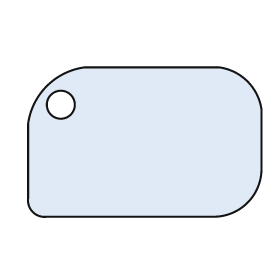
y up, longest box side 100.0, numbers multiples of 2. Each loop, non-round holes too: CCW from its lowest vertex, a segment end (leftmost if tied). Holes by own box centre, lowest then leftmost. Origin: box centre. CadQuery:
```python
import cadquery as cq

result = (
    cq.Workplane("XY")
    .moveTo(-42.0, -32.0)
    .lineTo(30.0, -32.0)
    .threePointArc((44.0, -26.0), (50.0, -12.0))
    .lineTo(50.0, 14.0)
    .threePointArc((44.0, 26.0), (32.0, 32.0))
    .lineTo(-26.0, 32.0)
    .threePointArc((-42.0, 24.0), (-50.0, 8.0))
    .lineTo(-50.0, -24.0)
    .threePointArc((-48.0, -30.0), (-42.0, -32.0))
    .close()
    .moveTo(-36.0, 16.0)
    .circle(6.0)
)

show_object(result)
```